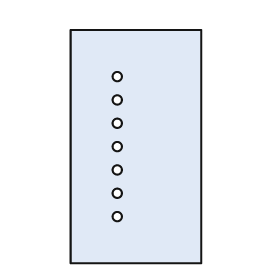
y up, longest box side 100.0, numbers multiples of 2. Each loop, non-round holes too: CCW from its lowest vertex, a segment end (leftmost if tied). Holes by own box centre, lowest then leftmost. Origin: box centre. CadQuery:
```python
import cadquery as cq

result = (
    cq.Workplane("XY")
    .moveTo(-28.0, -50.0)
    .lineTo(28.0, -50.0)
    .lineTo(28.0, 50.0)
    .lineTo(-28.0, 50.0)
    .close()
    .moveTo(-8.0, -30.0)
    .circle(2.0)
    .moveTo(-8.0, -20.0)
    .circle(2.0)
    .moveTo(-8.0, -10.0)
    .circle(2.0)
    .moveTo(-8.0, 0.0)
    .circle(2.0)
    .moveTo(-8.0, 10.0)
    .circle(2.0)
    .moveTo(-8.0, 20.0)
    .circle(2.0)
    .moveTo(-8.0, 30.0)
    .circle(2.0)
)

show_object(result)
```